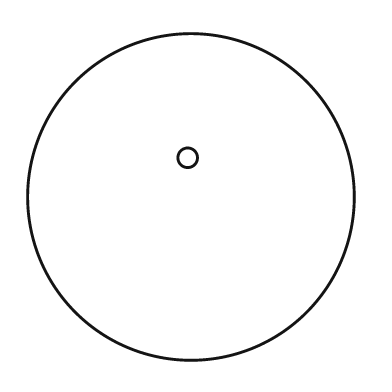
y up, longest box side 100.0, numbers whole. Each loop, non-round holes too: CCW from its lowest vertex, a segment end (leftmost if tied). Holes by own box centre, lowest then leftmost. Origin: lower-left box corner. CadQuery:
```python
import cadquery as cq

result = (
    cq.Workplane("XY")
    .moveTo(50.0, 50.0)
    .circle(50.0)
    .moveTo(49.0, 62.0)
    .circle(3.0)
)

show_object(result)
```